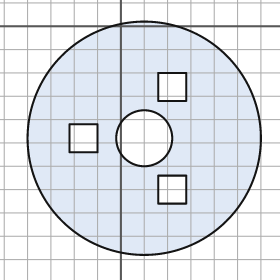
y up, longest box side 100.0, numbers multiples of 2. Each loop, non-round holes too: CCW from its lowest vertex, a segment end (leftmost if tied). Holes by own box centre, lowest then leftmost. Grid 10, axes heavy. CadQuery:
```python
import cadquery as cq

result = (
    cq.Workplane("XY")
    .moveTo(10.0, -48.0)
    .circle(50.0)
    .moveTo(16.0, -76.0)
    .lineTo(28.0, -76.0)
    .lineTo(28.0, -64.0)
    .lineTo(16.0, -64.0)
    .close()
    .moveTo(-22.0, -54.0)
    .lineTo(-10.0, -54.0)
    .lineTo(-10.0, -42.0)
    .lineTo(-22.0, -42.0)
    .close()
    .moveTo(10.0, -48.0)
    .circle(12.0)
    .moveTo(16.0, -32.0)
    .lineTo(28.0, -32.0)
    .lineTo(28.0, -20.0)
    .lineTo(16.0, -20.0)
    .close()
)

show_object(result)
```